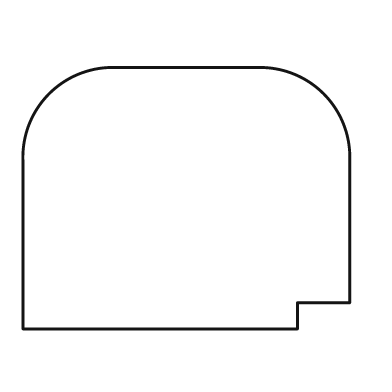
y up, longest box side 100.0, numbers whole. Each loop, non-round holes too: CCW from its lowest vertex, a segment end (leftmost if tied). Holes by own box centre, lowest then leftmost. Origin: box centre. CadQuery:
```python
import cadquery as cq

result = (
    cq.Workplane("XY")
    .moveTo(-50.0, -40.0)
    .lineTo(34.0, -40.0)
    .lineTo(34.0, -32.0)
    .lineTo(50.0, -32.0)
    .lineTo(50.0, 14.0)
    .threePointArc((42.0, 32.0), (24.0, 40.0))
    .lineTo(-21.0, 40.0)
    .threePointArc((-42.0, 32.0), (-50.0, 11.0))
    .close()
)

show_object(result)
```